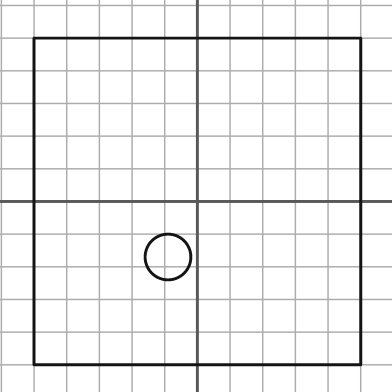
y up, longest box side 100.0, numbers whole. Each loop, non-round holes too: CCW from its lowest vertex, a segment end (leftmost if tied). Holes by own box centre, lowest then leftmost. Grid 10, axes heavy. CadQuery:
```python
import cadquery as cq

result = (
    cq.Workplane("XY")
    .moveTo(-50.0, -50.0)
    .lineTo(50.0, -50.0)
    .lineTo(50.0, 50.0)
    .lineTo(-50.0, 50.0)
    .close()
    .moveTo(-9.0, -17.0)
    .circle(7.0)
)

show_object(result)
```